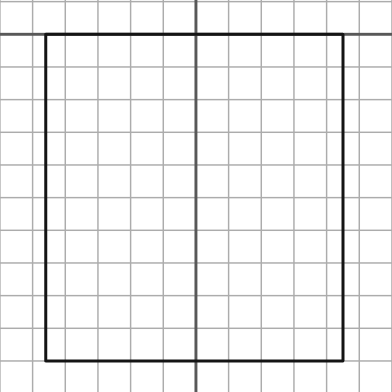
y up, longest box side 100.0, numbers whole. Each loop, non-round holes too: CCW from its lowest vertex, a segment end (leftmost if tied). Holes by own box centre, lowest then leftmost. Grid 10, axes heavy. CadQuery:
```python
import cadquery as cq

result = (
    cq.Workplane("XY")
    .moveTo(-46.0, -100.0)
    .lineTo(45.0, -100.0)
    .lineTo(45.0, 0.0)
    .lineTo(-46.0, 0.0)
    .close()
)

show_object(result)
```